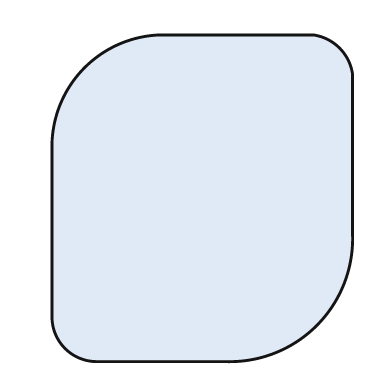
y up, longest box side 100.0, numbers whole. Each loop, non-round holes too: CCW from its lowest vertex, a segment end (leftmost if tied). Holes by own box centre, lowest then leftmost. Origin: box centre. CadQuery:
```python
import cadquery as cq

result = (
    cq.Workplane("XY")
    .moveTo(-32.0, -50.0)
    .lineTo(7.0, -50.0)
    .threePointArc((35.0, -39.0), (46.0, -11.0))
    .lineTo(46.0, 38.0)
    .threePointArc((42.0, 46.0), (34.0, 50.0))
    .lineTo(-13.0, 50.0)
    .threePointArc((-36.0, 40.0), (-46.0, 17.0))
    .lineTo(-46.0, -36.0)
    .threePointArc((-42.0, -46.0), (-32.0, -50.0))
    .close()
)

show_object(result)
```